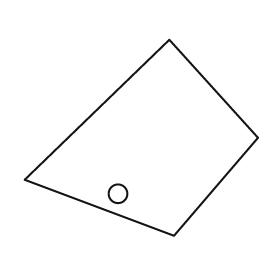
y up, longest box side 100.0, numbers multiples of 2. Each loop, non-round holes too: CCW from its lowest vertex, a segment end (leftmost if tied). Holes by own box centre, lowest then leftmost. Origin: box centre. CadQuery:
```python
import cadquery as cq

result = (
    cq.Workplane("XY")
    .moveTo(14.0, -42.0)
    .lineTo(50.0, 0.0)
    .lineTo(12.0, 42.0)
    .lineTo(-50.0, -18.0)
    .close()
    .moveTo(-10.0, -24.0)
    .circle(4.0)
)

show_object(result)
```